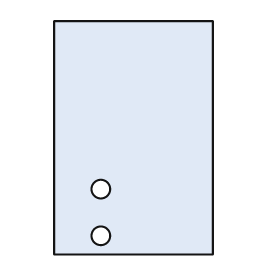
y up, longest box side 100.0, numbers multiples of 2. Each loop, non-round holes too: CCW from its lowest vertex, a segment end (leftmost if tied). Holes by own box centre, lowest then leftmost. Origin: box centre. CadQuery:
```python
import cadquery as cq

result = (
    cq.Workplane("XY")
    .moveTo(-34.0, -50.0)
    .lineTo(34.0, -50.0)
    .lineTo(34.0, 50.0)
    .lineTo(-34.0, 50.0)
    .close()
    .moveTo(-14.0, -42.0)
    .circle(4.0)
    .moveTo(-14.0, -22.0)
    .circle(4.0)
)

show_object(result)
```